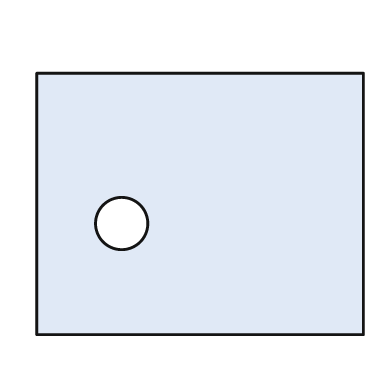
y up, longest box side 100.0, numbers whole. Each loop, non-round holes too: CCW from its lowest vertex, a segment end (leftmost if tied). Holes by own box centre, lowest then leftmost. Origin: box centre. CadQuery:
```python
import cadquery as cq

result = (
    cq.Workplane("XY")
    .moveTo(-50.0, -40.0)
    .lineTo(50.0, -40.0)
    .lineTo(50.0, 40.0)
    .lineTo(-50.0, 40.0)
    .close()
    .moveTo(-24.0, -6.0)
    .circle(8.0)
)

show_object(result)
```